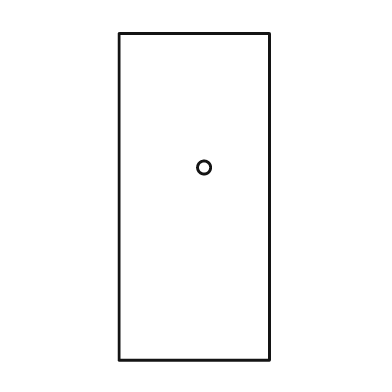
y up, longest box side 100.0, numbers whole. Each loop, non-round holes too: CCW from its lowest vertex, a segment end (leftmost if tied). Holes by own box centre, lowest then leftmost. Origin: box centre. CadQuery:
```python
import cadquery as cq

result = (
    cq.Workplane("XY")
    .moveTo(-23.0, -50.0)
    .lineTo(23.0, -50.0)
    .lineTo(23.0, 50.0)
    .lineTo(-23.0, 50.0)
    .close()
    .moveTo(3.0, 9.0)
    .circle(2.0)
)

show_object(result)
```